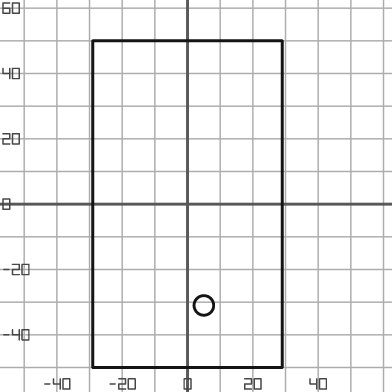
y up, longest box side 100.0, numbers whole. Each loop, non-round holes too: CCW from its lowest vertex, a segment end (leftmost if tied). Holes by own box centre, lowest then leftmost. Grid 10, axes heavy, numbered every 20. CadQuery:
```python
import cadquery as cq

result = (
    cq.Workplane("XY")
    .moveTo(-29.0, -50.0)
    .lineTo(29.0, -50.0)
    .lineTo(29.0, 50.0)
    .lineTo(-29.0, 50.0)
    .close()
    .moveTo(5.0, -31.0)
    .circle(3.0)
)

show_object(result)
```